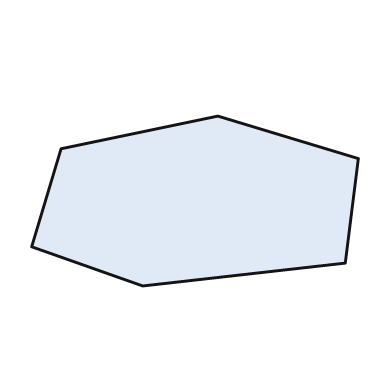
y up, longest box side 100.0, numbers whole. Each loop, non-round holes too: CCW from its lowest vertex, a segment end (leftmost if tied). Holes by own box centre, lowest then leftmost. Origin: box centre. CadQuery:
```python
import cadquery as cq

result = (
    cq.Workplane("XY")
    .moveTo(-16.0, -26.0)
    .lineTo(46.0, -19.0)
    .lineTo(50.0, 13.0)
    .lineTo(7.0, 26.0)
    .lineTo(-41.0, 16.0)
    .lineTo(-50.0, -14.0)
    .close()
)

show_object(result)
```